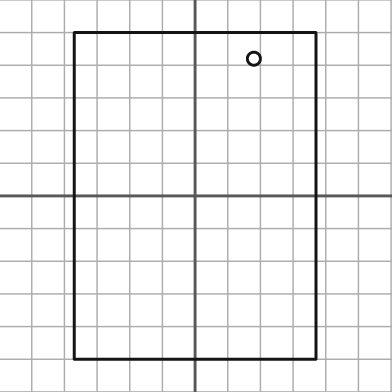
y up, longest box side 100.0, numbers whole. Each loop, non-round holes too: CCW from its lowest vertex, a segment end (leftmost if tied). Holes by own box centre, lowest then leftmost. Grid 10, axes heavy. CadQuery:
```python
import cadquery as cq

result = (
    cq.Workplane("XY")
    .moveTo(-37.0, -50.0)
    .lineTo(37.0, -50.0)
    .lineTo(37.0, 50.0)
    .lineTo(-37.0, 50.0)
    .close()
    .moveTo(18.0, 42.0)
    .circle(2.0)
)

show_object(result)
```